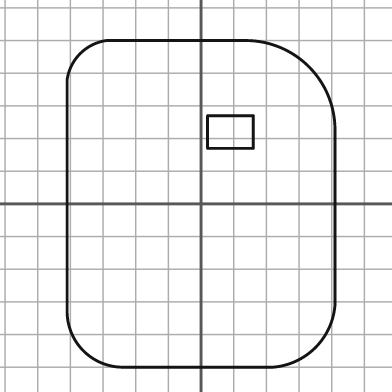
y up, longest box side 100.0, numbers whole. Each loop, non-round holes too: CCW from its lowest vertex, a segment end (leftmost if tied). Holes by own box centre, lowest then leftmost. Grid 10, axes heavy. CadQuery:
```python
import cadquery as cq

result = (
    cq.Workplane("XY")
    .moveTo(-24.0, -50.0)
    .lineTo(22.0, -50.0)
    .threePointArc((35.0, -44.0), (41.0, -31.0))
    .lineTo(41.0, 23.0)
    .threePointArc((33.0, 42.0), (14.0, 50.0))
    .lineTo(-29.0, 50.0)
    .threePointArc((-37.0, 46.0), (-41.0, 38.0))
    .lineTo(-41.0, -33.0)
    .threePointArc((-36.0, -45.0), (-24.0, -50.0))
    .close()
    .moveTo(2.0, 17.0)
    .lineTo(16.0, 17.0)
    .lineTo(16.0, 27.0)
    .lineTo(2.0, 27.0)
    .close()
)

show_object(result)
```